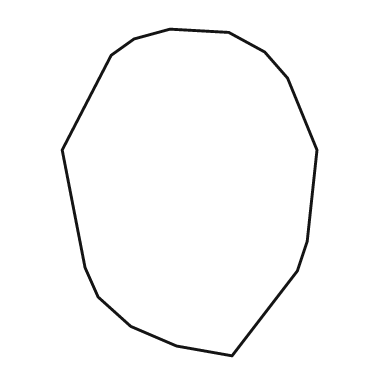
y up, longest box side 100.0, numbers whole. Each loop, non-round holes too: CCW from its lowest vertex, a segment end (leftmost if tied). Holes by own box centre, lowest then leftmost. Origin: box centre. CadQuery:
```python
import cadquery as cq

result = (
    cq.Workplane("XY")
    .moveTo(13.0, -50.0)
    .lineTo(33.0, -24.0)
    .lineTo(36.0, -15.0)
    .lineTo(39.0, 13.0)
    .lineTo(30.0, 35.0)
    .lineTo(23.0, 43.0)
    .lineTo(12.0, 49.0)
    .lineTo(-6.0, 50.0)
    .lineTo(-17.0, 47.0)
    .lineTo(-24.0, 42.0)
    .lineTo(-39.0, 13.0)
    .lineTo(-32.0, -23.0)
    .lineTo(-28.0, -32.0)
    .lineTo(-18.0, -41.0)
    .lineTo(-4.0, -47.0)
    .close()
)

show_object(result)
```